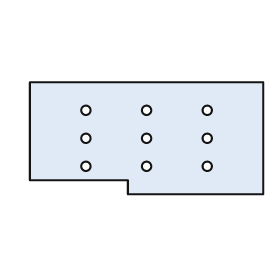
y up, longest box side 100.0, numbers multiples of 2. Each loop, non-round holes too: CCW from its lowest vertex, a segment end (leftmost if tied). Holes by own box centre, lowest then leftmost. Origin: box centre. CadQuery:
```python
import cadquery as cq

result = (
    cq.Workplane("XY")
    .moveTo(-8.0, -24.0)
    .lineTo(50.0, -24.0)
    .lineTo(50.0, 24.0)
    .lineTo(-50.0, 24.0)
    .lineTo(-50.0, -18.0)
    .lineTo(-8.0, -18.0)
    .close()
    .moveTo(-26.0, -12.0)
    .circle(2.0)
    .moveTo(0.0, -12.0)
    .circle(2.0)
    .moveTo(26.0, -12.0)
    .circle(2.0)
    .moveTo(-26.0, 0.0)
    .circle(2.0)
    .moveTo(0.0, 0.0)
    .circle(2.0)
    .moveTo(26.0, 0.0)
    .circle(2.0)
    .moveTo(-26.0, 12.0)
    .circle(2.0)
    .moveTo(0.0, 12.0)
    .circle(2.0)
    .moveTo(26.0, 12.0)
    .circle(2.0)
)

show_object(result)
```